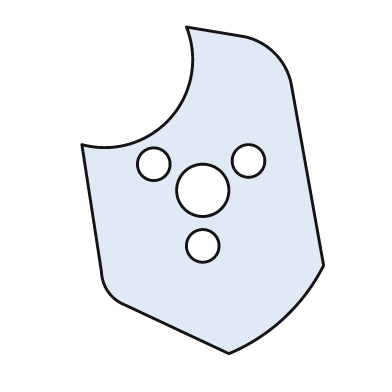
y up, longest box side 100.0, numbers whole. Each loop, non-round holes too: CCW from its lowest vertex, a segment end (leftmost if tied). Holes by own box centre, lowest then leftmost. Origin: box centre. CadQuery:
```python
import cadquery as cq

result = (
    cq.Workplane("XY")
    .moveTo(8.0, -50.0)
    .threePointArc((25.0, -39.0), (37.0, -23.0))
    .lineTo(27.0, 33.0)
    .threePointArc((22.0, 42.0), (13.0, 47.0))
    .lineTo(-5.0, 50.0)
    .threePointArc((-10.0, 22.0), (-37.0, 14.0))
    .lineTo(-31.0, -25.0)
    .threePointArc((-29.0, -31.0), (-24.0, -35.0))
    .close()
    .moveTo(0.0, -17.0)
    .circle(5.0)
    .moveTo(0.0, 0.0)
    .circle(8.0)
    .moveTo(-15.0, 8.0)
    .circle(5.0)
    .moveTo(14.0, 9.0)
    .circle(5.0)
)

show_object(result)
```